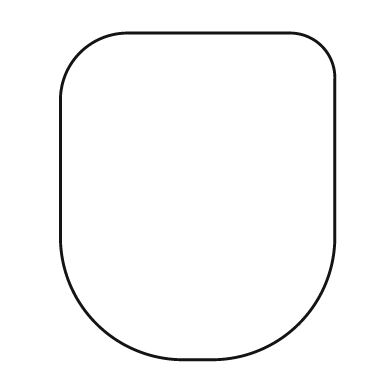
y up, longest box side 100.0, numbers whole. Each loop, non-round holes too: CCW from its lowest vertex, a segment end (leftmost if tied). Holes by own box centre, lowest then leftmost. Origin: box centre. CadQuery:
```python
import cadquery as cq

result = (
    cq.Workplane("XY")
    .moveTo(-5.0, -50.0)
    .lineTo(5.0, -50.0)
    .threePointArc((31.0, -39.0), (42.0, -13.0))
    .lineTo(42.0, 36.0)
    .threePointArc((38.0, 46.0), (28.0, 50.0))
    .lineTo(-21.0, 50.0)
    .threePointArc((-36.0, 44.0), (-42.0, 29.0))
    .lineTo(-42.0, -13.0)
    .threePointArc((-31.0, -39.0), (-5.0, -50.0))
    .close()
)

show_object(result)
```